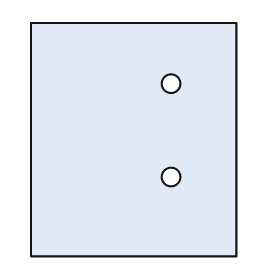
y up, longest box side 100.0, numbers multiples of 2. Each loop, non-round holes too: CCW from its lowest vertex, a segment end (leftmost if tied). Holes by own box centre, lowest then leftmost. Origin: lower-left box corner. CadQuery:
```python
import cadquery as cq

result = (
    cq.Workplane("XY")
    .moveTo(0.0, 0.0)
    .lineTo(88.0, 0.0)
    .lineTo(88.0, 100.0)
    .lineTo(0.0, 100.0)
    .close()
    .moveTo(60.0, 34.0)
    .circle(4.0)
    .moveTo(60.0, 74.0)
    .circle(4.0)
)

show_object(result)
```